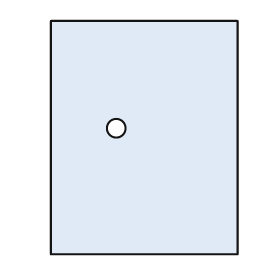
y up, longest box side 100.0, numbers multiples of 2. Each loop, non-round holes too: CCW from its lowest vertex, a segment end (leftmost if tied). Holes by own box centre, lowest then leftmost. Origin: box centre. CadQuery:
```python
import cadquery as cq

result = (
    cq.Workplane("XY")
    .moveTo(-40.0, -50.0)
    .lineTo(40.0, -50.0)
    .lineTo(40.0, 50.0)
    .lineTo(-40.0, 50.0)
    .close()
    .moveTo(-12.0, 4.0)
    .circle(4.0)
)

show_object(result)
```